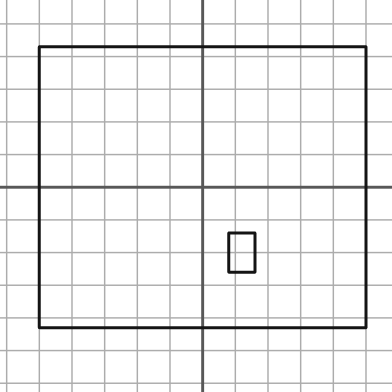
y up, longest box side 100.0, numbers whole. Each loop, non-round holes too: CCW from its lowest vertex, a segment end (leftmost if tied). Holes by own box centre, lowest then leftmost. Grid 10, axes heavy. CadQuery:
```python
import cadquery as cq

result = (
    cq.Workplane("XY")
    .moveTo(-50.0, -43.0)
    .lineTo(50.0, -43.0)
    .lineTo(50.0, 43.0)
    .lineTo(-50.0, 43.0)
    .close()
    .moveTo(8.0, -26.0)
    .lineTo(16.0, -26.0)
    .lineTo(16.0, -14.0)
    .lineTo(8.0, -14.0)
    .close()
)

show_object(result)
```